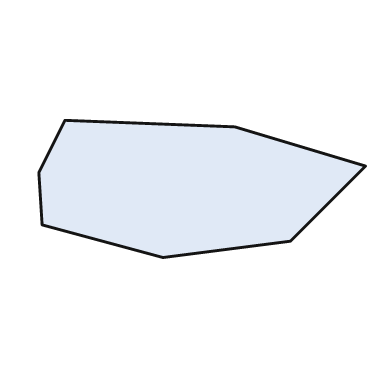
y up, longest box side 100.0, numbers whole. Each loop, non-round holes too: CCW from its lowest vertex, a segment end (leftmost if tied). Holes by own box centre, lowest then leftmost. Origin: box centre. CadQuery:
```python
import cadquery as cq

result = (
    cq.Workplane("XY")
    .moveTo(-12.0, -21.0)
    .lineTo(27.0, -16.0)
    .lineTo(50.0, 7.0)
    .lineTo(10.0, 19.0)
    .lineTo(-42.0, 21.0)
    .lineTo(-50.0, 5.0)
    .lineTo(-49.0, -11.0)
    .close()
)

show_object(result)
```